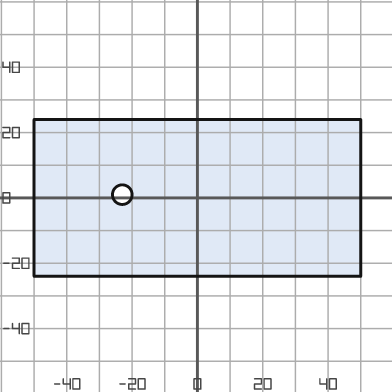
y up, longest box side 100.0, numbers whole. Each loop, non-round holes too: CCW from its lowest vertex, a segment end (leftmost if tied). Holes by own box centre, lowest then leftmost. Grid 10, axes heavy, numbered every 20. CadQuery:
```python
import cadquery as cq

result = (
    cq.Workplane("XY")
    .moveTo(-50.0, -24.0)
    .lineTo(50.0, -24.0)
    .lineTo(50.0, 24.0)
    .lineTo(-50.0, 24.0)
    .close()
    .moveTo(-23.0, 1.0)
    .circle(3.0)
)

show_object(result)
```